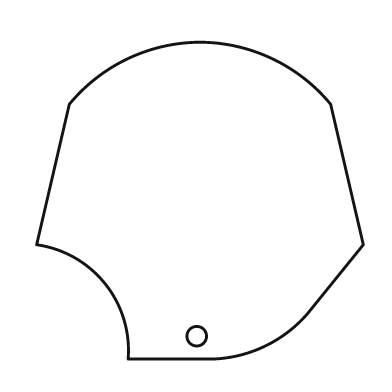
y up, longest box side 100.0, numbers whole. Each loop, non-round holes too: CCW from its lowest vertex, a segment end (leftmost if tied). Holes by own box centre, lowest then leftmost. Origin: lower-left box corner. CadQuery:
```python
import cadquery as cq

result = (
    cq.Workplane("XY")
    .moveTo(28.0, 0.0)
    .lineTo(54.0, 0.0)
    .threePointArc((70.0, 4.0), (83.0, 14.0))
    .lineTo(100.0, 35.0)
    .lineTo(90.0, 78.0)
    .threePointArc((72.0, 92.0), (50.0, 97.0))
    .threePointArc((28.0, 92.0), (10.0, 78.0))
    .lineTo(0.0, 35.0)
    .threePointArc((21.0, 23.0), (28.0, 0.0))
    .close()
    .moveTo(49.0, 7.0)
    .circle(3.0)
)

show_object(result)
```